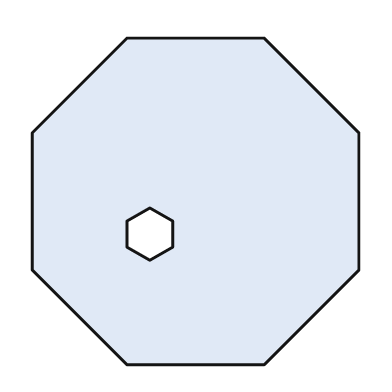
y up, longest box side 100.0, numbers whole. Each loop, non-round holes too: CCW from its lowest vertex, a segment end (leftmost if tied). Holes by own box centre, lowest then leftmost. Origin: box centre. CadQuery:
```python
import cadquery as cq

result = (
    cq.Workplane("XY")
    .moveTo(-21.0, -50.0)
    .lineTo(21.0, -50.0)
    .lineTo(50.0, -21.0)
    .lineTo(50.0, 21.0)
    .lineTo(21.0, 50.0)
    .lineTo(-21.0, 50.0)
    .lineTo(-50.0, 21.0)
    .lineTo(-50.0, -21.0)
    .close()
    .moveTo(-14.0, -18.0)
    .lineTo(-7.0, -14.0)
    .lineTo(-7.0, -6.0)
    .lineTo(-14.0, -2.0)
    .lineTo(-21.0, -6.0)
    .lineTo(-21.0, -14.0)
    .close()
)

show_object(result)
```